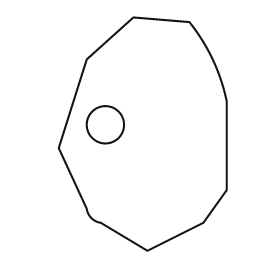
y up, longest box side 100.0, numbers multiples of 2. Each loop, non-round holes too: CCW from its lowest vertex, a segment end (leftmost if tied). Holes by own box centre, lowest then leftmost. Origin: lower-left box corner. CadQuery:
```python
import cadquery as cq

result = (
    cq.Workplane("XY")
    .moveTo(38.0, 0.0)
    .lineTo(62.0, 12.0)
    .lineTo(72.0, 26.0)
    .lineTo(72.0, 64.0)
    .threePointArc((66.0, 82.0), (56.0, 98.0))
    .lineTo(32.0, 100.0)
    .lineTo(12.0, 82.0)
    .lineTo(0.0, 44.0)
    .lineTo(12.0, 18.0)
    .threePointArc((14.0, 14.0), (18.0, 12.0))
    .close()
    .moveTo(20.0, 54.0)
    .circle(8.0)
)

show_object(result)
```